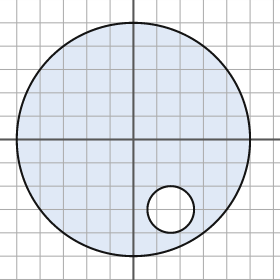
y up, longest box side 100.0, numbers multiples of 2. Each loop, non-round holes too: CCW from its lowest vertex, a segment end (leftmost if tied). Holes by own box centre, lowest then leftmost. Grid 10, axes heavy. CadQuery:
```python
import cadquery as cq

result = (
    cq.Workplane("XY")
    .moveTo(0.0, 0.0)
    .circle(50.0)
    .moveTo(16.0, -30.0)
    .circle(10.0)
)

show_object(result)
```